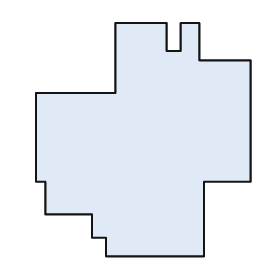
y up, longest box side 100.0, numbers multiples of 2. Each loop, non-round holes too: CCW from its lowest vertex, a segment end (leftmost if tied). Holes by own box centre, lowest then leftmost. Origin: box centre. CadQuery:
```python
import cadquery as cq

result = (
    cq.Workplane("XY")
    .moveTo(-16.0, -50.0)
    .lineTo(26.0, -50.0)
    .lineTo(26.0, -18.0)
    .lineTo(46.0, -18.0)
    .lineTo(46.0, 34.0)
    .lineTo(24.0, 34.0)
    .lineTo(24.0, 50.0)
    .lineTo(16.0, 50.0)
    .lineTo(16.0, 38.0)
    .lineTo(10.0, 38.0)
    .lineTo(10.0, 50.0)
    .lineTo(-12.0, 50.0)
    .lineTo(-12.0, 20.0)
    .lineTo(-46.0, 20.0)
    .lineTo(-46.0, -18.0)
    .lineTo(-42.0, -18.0)
    .lineTo(-42.0, -32.0)
    .lineTo(-22.0, -32.0)
    .lineTo(-22.0, -42.0)
    .lineTo(-16.0, -42.0)
    .close()
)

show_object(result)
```